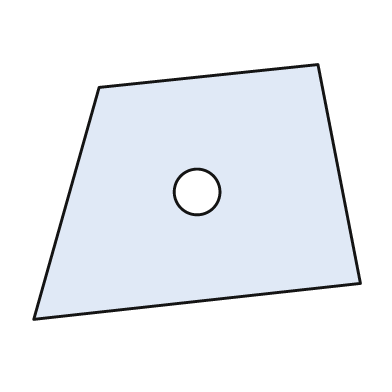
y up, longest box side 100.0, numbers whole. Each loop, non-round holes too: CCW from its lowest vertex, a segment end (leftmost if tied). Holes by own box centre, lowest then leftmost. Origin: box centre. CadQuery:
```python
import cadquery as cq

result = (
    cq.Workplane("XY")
    .moveTo(-50.0, -39.0)
    .lineTo(50.0, -28.0)
    .lineTo(37.0, 39.0)
    .lineTo(-30.0, 32.0)
    .close()
    .moveTo(0.0, 0.0)
    .circle(7.0)
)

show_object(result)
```